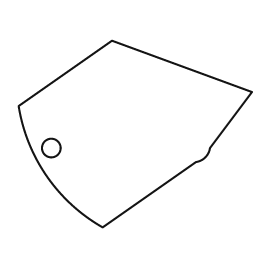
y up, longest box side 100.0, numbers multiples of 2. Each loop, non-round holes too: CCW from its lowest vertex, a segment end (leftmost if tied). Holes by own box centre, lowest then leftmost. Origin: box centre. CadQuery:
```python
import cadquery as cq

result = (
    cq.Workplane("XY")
    .moveTo(-14.0, -40.0)
    .lineTo(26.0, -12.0)
    .threePointArc((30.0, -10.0), (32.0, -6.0))
    .lineTo(50.0, 18.0)
    .lineTo(-10.0, 40.0)
    .lineTo(-50.0, 12.0)
    .threePointArc((-38.0, -18.0), (-14.0, -40.0))
    .close()
    .moveTo(-36.0, -6.0)
    .circle(4.0)
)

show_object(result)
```